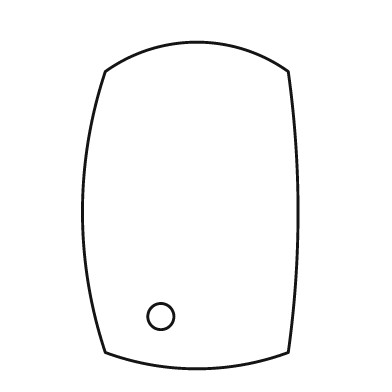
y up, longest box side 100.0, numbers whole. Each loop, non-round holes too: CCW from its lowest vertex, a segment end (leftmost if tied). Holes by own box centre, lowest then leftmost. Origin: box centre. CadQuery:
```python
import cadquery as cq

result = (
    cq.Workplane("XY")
    .moveTo(-26.0, -45.0)
    .threePointArc((2.0, -50.0), (30.0, -45.0))
    .threePointArc((33.0, -2.0), (30.0, 41.0))
    .threePointArc((2.0, 50.0), (-26.0, 41.0))
    .threePointArc((-33.0, -2.0), (-26.0, -45.0))
    .close()
    .moveTo(-9.0, -34.0)
    .circle(4.0)
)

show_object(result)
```